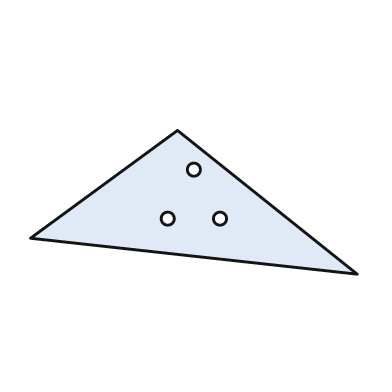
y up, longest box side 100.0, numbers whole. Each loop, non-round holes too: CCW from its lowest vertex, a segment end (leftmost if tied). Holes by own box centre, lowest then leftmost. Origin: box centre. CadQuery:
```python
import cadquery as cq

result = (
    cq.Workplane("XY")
    .moveTo(50.0, -22.0)
    .lineTo(-5.0, 22.0)
    .lineTo(-50.0, -11.0)
    .close()
    .moveTo(-8.0, -5.0)
    .circle(2.0)
    .moveTo(8.0, -5.0)
    .circle(2.0)
    .moveTo(0.0, 10.0)
    .circle(2.0)
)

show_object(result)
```